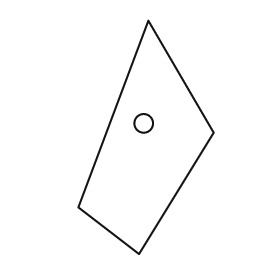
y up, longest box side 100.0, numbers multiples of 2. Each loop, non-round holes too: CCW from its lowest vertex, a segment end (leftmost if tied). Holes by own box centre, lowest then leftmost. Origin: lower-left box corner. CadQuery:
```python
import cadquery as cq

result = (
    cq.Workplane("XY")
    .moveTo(26.0, 0.0)
    .lineTo(58.0, 52.0)
    .lineTo(30.0, 100.0)
    .lineTo(0.0, 20.0)
    .close()
    .moveTo(28.0, 56.0)
    .circle(4.0)
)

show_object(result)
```